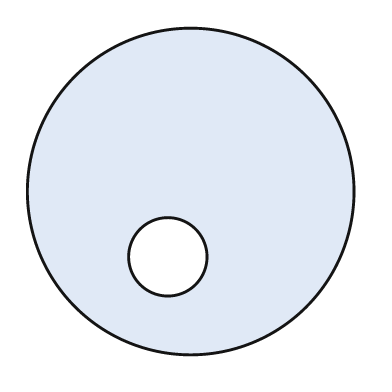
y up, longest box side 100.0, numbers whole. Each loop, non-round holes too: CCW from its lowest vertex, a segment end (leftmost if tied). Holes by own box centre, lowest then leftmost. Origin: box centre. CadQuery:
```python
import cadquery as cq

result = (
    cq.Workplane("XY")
    .moveTo(0.0, 0.0)
    .circle(50.0)
    .moveTo(-7.0, -20.0)
    .circle(12.0)
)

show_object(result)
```